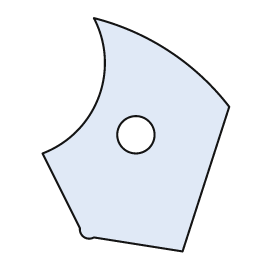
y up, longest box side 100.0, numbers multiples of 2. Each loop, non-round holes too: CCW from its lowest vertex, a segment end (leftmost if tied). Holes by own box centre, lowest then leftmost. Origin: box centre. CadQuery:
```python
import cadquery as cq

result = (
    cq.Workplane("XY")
    .moveTo(20.0, -50.0)
    .lineTo(40.0, 12.0)
    .threePointArc((14.0, 36.0), (-18.0, 50.0))
    .threePointArc((-16.0, 16.0), (-40.0, -8.0))
    .lineTo(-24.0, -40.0)
    .threePointArc((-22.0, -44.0), (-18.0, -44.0))
    .close()
    .moveTo(0.0, 0.0)
    .circle(8.0)
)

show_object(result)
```